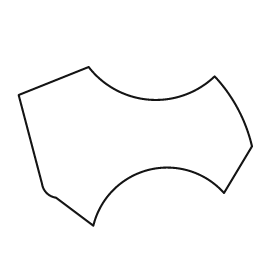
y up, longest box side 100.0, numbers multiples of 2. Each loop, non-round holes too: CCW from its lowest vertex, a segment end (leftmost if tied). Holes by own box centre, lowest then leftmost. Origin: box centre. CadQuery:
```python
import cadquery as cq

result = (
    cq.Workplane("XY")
    .moveTo(-18.0, -34.0)
    .threePointArc((6.0, -10.0), (38.0, -20.0))
    .lineTo(50.0, 0.0)
    .threePointArc((44.0, 16.0), (34.0, 30.0))
    .threePointArc((6.0, 20.0), (-20.0, 34.0))
    .lineTo(-50.0, 22.0)
    .lineTo(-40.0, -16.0)
    .threePointArc((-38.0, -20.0), (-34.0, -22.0))
    .close()
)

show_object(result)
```